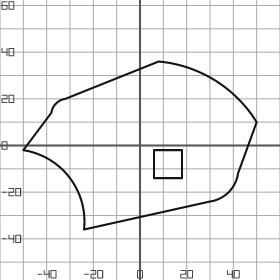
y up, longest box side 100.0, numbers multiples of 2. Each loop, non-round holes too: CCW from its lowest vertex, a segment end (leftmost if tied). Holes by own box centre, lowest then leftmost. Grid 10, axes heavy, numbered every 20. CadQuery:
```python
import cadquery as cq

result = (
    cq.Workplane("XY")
    .moveTo(-24.0, -36.0)
    .lineTo(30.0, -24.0)
    .threePointArc((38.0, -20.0), (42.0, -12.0))
    .lineTo(50.0, 10.0)
    .threePointArc((32.0, 28.0), (8.0, 36.0))
    .lineTo(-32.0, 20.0)
    .threePointArc((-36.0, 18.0), (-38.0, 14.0))
    .lineTo(-50.0, -2.0)
    .threePointArc((-30.0, -14.0), (-24.0, -36.0))
    .close()
    .moveTo(6.0, -14.0)
    .lineTo(18.0, -14.0)
    .lineTo(18.0, -2.0)
    .lineTo(6.0, -2.0)
    .close()
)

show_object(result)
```